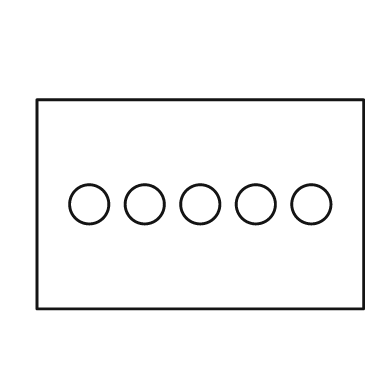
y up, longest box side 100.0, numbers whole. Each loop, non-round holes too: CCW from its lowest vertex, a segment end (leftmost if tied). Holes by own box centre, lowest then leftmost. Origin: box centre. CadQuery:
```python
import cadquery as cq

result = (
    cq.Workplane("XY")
    .moveTo(-50.0, -32.0)
    .lineTo(50.0, -32.0)
    .lineTo(50.0, 32.0)
    .lineTo(-50.0, 32.0)
    .close()
    .moveTo(-34.0, 0.0)
    .circle(6.0)
    .moveTo(-17.0, 0.0)
    .circle(6.0)
    .moveTo(0.0, 0.0)
    .circle(6.0)
    .moveTo(17.0, 0.0)
    .circle(6.0)
    .moveTo(34.0, 0.0)
    .circle(6.0)
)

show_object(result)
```